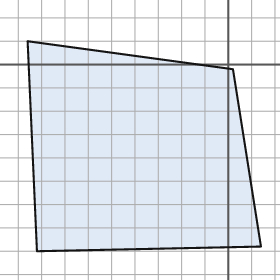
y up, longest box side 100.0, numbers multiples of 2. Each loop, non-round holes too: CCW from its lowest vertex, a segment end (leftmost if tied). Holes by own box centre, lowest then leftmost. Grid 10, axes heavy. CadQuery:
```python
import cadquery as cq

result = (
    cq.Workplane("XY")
    .moveTo(-82.0, -80.0)
    .lineTo(14.0, -78.0)
    .lineTo(2.0, -2.0)
    .lineTo(-86.0, 10.0)
    .close()
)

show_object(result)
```